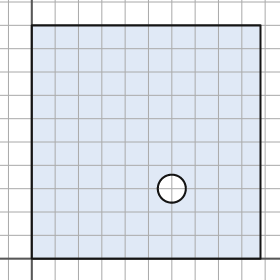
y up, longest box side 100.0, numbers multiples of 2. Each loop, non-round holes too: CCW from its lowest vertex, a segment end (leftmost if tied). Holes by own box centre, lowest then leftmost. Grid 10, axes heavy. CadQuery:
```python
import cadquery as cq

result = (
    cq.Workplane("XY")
    .moveTo(0.0, 0.0)
    .lineTo(98.0, 0.0)
    .lineTo(98.0, 100.0)
    .lineTo(0.0, 100.0)
    .close()
    .moveTo(60.0, 30.0)
    .circle(6.0)
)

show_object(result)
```